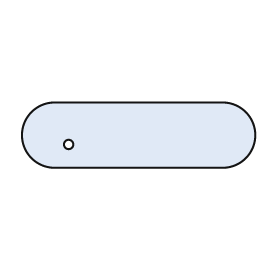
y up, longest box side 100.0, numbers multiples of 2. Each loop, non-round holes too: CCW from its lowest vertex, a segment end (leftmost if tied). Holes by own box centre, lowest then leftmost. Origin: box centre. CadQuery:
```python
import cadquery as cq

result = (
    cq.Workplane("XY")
    .moveTo(-36.0, -14.0)
    .lineTo(36.0, -14.0)
    .threePointArc((50.0, 0.0), (36.0, 14.0))
    .lineTo(-36.0, 14.0)
    .threePointArc((-50.0, 0.0), (-36.0, -14.0))
    .close()
    .moveTo(-30.0, -4.0)
    .circle(2.0)
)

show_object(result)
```